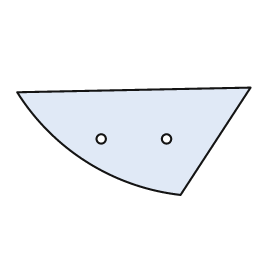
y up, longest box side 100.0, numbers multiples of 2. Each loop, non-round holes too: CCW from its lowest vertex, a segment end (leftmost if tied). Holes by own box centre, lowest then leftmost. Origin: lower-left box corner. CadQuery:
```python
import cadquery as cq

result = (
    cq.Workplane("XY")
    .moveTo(70.0, 0.0)
    .lineTo(100.0, 46.0)
    .lineTo(0.0, 44.0)
    .threePointArc((30.0, 14.0), (70.0, 0.0))
    .close()
    .moveTo(36.0, 24.0)
    .circle(2.0)
    .moveTo(64.0, 24.0)
    .circle(2.0)
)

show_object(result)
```